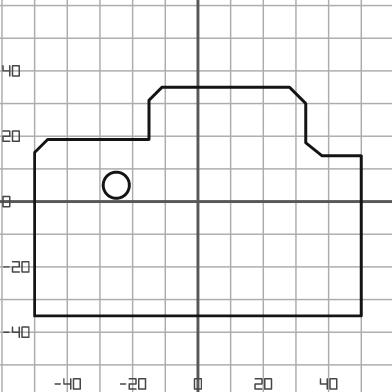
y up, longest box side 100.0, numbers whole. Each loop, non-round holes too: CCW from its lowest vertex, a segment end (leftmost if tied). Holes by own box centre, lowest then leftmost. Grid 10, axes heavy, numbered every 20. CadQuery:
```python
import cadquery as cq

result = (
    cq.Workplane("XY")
    .moveTo(-50.0, -35.0)
    .lineTo(50.0, -35.0)
    .lineTo(50.0, 14.0)
    .lineTo(38.0, 14.0)
    .lineTo(33.0, 18.0)
    .lineTo(33.0, 30.0)
    .lineTo(28.0, 35.0)
    .lineTo(-11.0, 35.0)
    .lineTo(-15.0, 31.0)
    .lineTo(-15.0, 19.0)
    .lineTo(-46.0, 19.0)
    .lineTo(-50.0, 15.0)
    .close()
    .moveTo(-25.0, 5.0)
    .circle(4.0)
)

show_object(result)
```